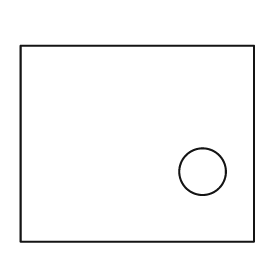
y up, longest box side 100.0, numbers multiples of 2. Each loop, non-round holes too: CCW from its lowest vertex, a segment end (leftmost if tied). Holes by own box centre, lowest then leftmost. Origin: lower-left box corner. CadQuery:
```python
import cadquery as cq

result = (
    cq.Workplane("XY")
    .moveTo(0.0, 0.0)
    .lineTo(100.0, 0.0)
    .lineTo(100.0, 84.0)
    .lineTo(0.0, 84.0)
    .close()
    .moveTo(78.0, 30.0)
    .circle(10.0)
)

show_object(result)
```